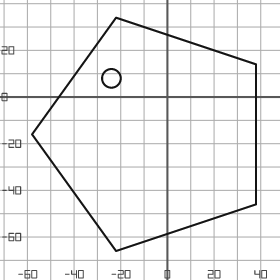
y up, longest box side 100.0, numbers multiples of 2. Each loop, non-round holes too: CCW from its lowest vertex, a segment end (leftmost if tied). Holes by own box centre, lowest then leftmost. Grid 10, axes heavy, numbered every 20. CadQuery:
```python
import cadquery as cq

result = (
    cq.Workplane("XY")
    .moveTo(-22.0, -66.0)
    .lineTo(38.0, -46.0)
    .lineTo(38.0, 14.0)
    .lineTo(-22.0, 34.0)
    .lineTo(-58.0, -16.0)
    .close()
    .moveTo(-24.0, 8.0)
    .circle(4.0)
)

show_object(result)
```